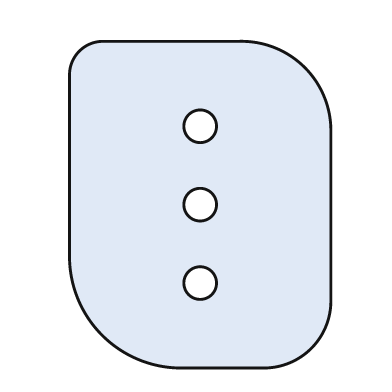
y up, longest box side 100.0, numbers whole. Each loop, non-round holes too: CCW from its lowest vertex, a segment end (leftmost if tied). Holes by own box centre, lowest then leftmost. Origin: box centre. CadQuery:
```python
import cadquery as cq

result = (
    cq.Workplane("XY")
    .moveTo(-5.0, -50.0)
    .lineTo(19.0, -50.0)
    .threePointArc((34.0, -44.0), (40.0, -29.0))
    .lineTo(40.0, 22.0)
    .threePointArc((32.0, 42.0), (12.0, 50.0))
    .lineTo(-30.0, 50.0)
    .threePointArc((-37.0, 47.0), (-40.0, 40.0))
    .lineTo(-40.0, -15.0)
    .threePointArc((-30.0, -40.0), (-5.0, -50.0))
    .close()
    .moveTo(0.0, -24.0)
    .circle(5.0)
    .moveTo(0.0, 0.0)
    .circle(5.0)
    .moveTo(0.0, 24.0)
    .circle(5.0)
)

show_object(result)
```